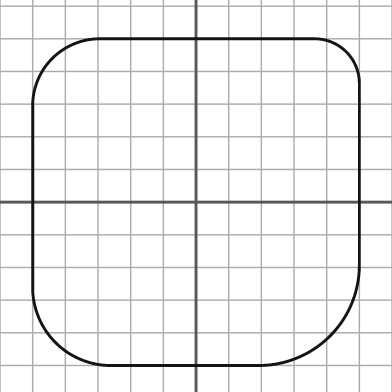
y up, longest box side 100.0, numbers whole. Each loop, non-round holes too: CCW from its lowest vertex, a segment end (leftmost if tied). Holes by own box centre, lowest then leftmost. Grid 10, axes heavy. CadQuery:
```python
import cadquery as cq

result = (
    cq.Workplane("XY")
    .moveTo(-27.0, -50.0)
    .lineTo(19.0, -50.0)
    .threePointArc((41.0, -41.0), (50.0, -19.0))
    .lineTo(50.0, 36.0)
    .threePointArc((46.0, 46.0), (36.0, 50.0))
    .lineTo(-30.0, 50.0)
    .threePointArc((-44.0, 44.0), (-50.0, 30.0))
    .lineTo(-50.0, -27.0)
    .threePointArc((-43.0, -43.0), (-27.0, -50.0))
    .close()
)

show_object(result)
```